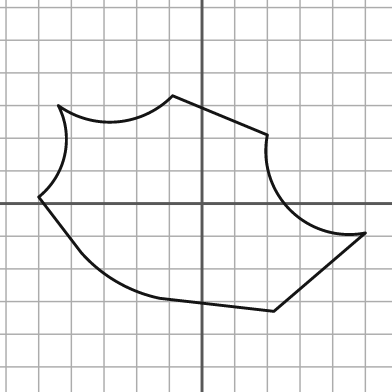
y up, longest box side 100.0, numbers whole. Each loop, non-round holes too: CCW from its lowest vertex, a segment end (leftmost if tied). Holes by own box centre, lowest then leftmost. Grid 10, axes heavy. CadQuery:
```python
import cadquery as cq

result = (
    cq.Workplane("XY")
    .moveTo(22.0, -33.0)
    .lineTo(50.0, -9.0)
    .threePointArc((27.0, -2.0), (20.0, 21.0))
    .lineTo(-9.0, 33.0)
    .threePointArc((-26.0, 25.0), (-44.0, 30.0))
    .threePointArc((-42.0, 15.0), (-50.0, 2.0))
    .lineTo(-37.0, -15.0)
    .threePointArc((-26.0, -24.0), (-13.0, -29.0))
    .close()
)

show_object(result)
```